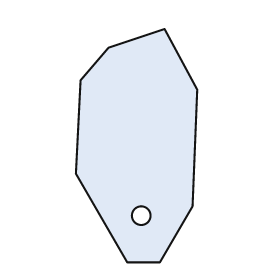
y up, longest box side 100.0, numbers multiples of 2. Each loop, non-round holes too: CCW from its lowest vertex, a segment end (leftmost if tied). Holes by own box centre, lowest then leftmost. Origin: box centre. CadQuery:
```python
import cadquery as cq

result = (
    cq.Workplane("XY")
    .moveTo(-4.0, -50.0)
    .lineTo(10.0, -50.0)
    .lineTo(24.0, -26.0)
    .lineTo(26.0, 24.0)
    .lineTo(12.0, 50.0)
    .lineTo(-12.0, 42.0)
    .lineTo(-24.0, 28.0)
    .lineTo(-26.0, -12.0)
    .close()
    .moveTo(2.0, -30.0)
    .circle(4.0)
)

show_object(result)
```